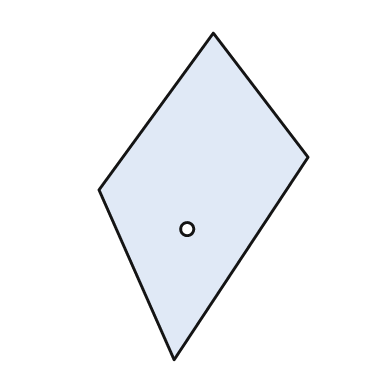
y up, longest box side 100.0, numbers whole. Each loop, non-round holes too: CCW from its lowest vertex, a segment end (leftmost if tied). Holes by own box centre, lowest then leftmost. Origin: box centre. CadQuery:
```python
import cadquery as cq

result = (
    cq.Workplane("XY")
    .moveTo(-9.0, -50.0)
    .lineTo(32.0, 12.0)
    .lineTo(3.0, 50.0)
    .lineTo(-32.0, 2.0)
    .close()
    .moveTo(-5.0, -10.0)
    .circle(2.0)
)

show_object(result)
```